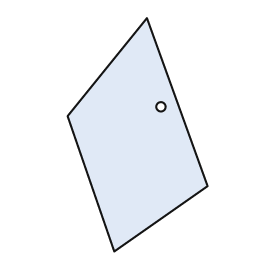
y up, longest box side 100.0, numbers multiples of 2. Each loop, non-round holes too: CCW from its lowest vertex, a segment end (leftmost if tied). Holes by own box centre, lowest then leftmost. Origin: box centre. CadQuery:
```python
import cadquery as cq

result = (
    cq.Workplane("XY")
    .moveTo(-10.0, -50.0)
    .lineTo(30.0, -22.0)
    .lineTo(4.0, 50.0)
    .lineTo(-30.0, 8.0)
    .close()
    .moveTo(10.0, 12.0)
    .circle(2.0)
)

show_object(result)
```